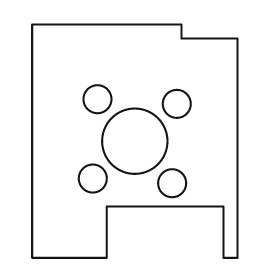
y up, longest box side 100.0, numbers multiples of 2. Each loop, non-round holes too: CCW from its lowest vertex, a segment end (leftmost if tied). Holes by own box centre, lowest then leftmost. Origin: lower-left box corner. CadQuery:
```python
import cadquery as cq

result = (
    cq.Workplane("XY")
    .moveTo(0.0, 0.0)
    .lineTo(32.0, 0.0)
    .lineTo(32.0, 22.0)
    .lineTo(82.0, 22.0)
    .lineTo(82.0, 0.0)
    .lineTo(88.0, 0.0)
    .lineTo(88.0, 94.0)
    .lineTo(64.0, 94.0)
    .lineTo(64.0, 100.0)
    .lineTo(0.0, 100.0)
    .close()
    .moveTo(60.0, 32.0)
    .circle(6.0)
    .moveTo(26.0, 34.0)
    .circle(6.0)
    .moveTo(44.0, 50.0)
    .circle(14.0)
    .moveTo(62.0, 66.0)
    .circle(6.0)
    .moveTo(28.0, 68.0)
    .circle(6.0)
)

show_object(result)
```